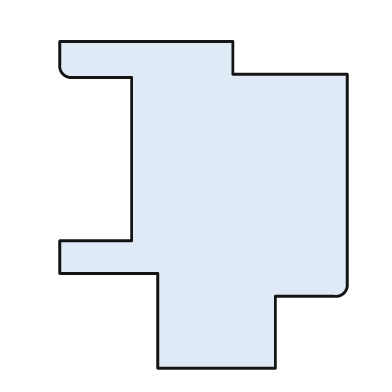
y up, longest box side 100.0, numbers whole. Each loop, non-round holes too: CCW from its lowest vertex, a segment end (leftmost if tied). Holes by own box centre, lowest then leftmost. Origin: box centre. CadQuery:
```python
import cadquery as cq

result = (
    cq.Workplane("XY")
    .moveTo(-14.0, -50.0)
    .lineTo(22.0, -50.0)
    .lineTo(22.0, -28.0)
    .lineTo(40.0, -28.0)
    .threePointArc((43.0, -27.0), (44.0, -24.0))
    .lineTo(44.0, 40.0)
    .lineTo(9.0, 40.0)
    .lineTo(9.0, 50.0)
    .lineTo(-44.0, 50.0)
    .lineTo(-44.0, 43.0)
    .threePointArc((-43.0, 40.0), (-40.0, 39.0))
    .lineTo(-22.0, 39.0)
    .lineTo(-22.0, -11.0)
    .lineTo(-44.0, -11.0)
    .lineTo(-44.0, -21.0)
    .lineTo(-14.0, -21.0)
    .close()
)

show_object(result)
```